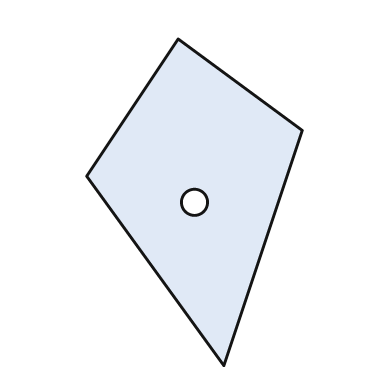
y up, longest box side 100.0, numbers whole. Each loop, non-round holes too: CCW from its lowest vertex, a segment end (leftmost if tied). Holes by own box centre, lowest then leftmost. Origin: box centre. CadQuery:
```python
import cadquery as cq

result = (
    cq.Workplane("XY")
    .moveTo(9.0, -50.0)
    .lineTo(33.0, 22.0)
    .lineTo(-5.0, 50.0)
    .lineTo(-33.0, 8.0)
    .close()
    .moveTo(0.0, 0.0)
    .circle(4.0)
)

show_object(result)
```